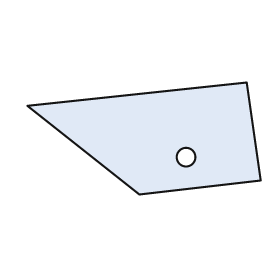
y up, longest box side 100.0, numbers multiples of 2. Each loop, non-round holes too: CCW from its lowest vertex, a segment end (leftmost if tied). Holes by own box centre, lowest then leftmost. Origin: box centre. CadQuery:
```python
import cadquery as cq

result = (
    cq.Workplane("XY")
    .moveTo(-2.0, -24.0)
    .lineTo(50.0, -18.0)
    .lineTo(44.0, 24.0)
    .lineTo(-50.0, 14.0)
    .close()
    .moveTo(18.0, -8.0)
    .circle(4.0)
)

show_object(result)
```